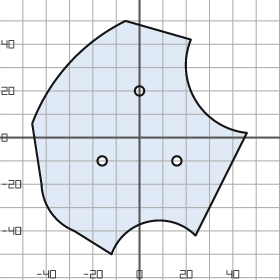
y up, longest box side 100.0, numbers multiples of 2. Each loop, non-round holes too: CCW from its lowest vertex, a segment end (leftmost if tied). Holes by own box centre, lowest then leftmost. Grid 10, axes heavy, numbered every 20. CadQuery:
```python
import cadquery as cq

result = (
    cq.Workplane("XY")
    .moveTo(-12.0, -50.0)
    .threePointArc((4.0, -36.0), (24.0, -42.0))
    .lineTo(46.0, 2.0)
    .threePointArc((24.0, 16.0), (22.0, 42.0))
    .lineTo(-6.0, 50.0)
    .threePointArc((-30.0, 32.0), (-46.0, 6.0))
    .lineTo(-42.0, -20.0)
    .threePointArc((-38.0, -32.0), (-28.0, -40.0))
    .close()
    .moveTo(-16.0, -10.0)
    .circle(2.0)
    .moveTo(16.0, -10.0)
    .circle(2.0)
    .moveTo(0.0, 20.0)
    .circle(2.0)
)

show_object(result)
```